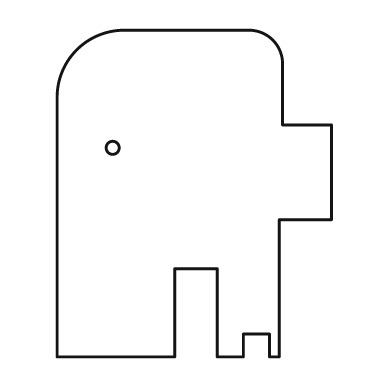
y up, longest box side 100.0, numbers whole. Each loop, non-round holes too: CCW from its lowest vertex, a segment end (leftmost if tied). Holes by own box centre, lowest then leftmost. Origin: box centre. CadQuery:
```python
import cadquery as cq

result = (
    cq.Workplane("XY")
    .moveTo(-42.0, -50.0)
    .lineTo(-6.0, -50.0)
    .lineTo(-6.0, -23.0)
    .lineTo(7.0, -23.0)
    .lineTo(7.0, -50.0)
    .lineTo(15.0, -50.0)
    .lineTo(15.0, -43.0)
    .lineTo(23.0, -43.0)
    .lineTo(23.0, -50.0)
    .lineTo(26.0, -50.0)
    .lineTo(26.0, -8.0)
    .lineTo(42.0, -8.0)
    .lineTo(42.0, 21.0)
    .lineTo(27.0, 21.0)
    .lineTo(27.0, 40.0)
    .threePointArc((24.0, 47.0), (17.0, 50.0))
    .lineTo(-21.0, 50.0)
    .threePointArc((-36.0, 44.0), (-42.0, 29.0))
    .close()
    .moveTo(-25.0, 14.0)
    .circle(2.0)
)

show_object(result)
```